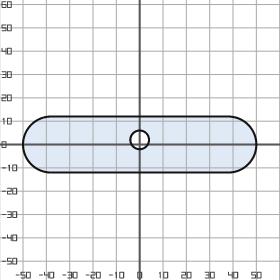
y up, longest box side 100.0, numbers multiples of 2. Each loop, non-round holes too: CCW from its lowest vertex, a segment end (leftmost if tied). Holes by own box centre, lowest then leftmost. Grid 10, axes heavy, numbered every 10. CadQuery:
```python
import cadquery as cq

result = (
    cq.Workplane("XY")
    .moveTo(-38.0, -12.0)
    .lineTo(38.0, -12.0)
    .threePointArc((50.0, 0.0), (38.0, 12.0))
    .lineTo(-38.0, 12.0)
    .threePointArc((-50.0, 0.0), (-38.0, -12.0))
    .close()
    .moveTo(0.0, 2.0)
    .circle(4.0)
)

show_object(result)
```